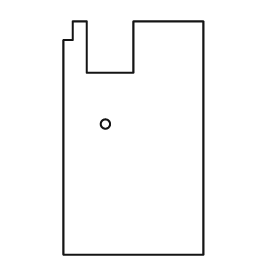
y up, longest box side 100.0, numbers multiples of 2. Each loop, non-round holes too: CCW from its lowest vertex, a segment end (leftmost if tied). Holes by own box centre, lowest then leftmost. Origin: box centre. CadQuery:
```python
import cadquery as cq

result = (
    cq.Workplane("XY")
    .moveTo(-30.0, -50.0)
    .lineTo(30.0, -50.0)
    .lineTo(30.0, 50.0)
    .lineTo(0.0, 50.0)
    .lineTo(0.0, 28.0)
    .lineTo(-20.0, 28.0)
    .lineTo(-20.0, 50.0)
    .lineTo(-26.0, 50.0)
    .lineTo(-26.0, 42.0)
    .lineTo(-30.0, 42.0)
    .close()
    .moveTo(-12.0, 6.0)
    .circle(2.0)
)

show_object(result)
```